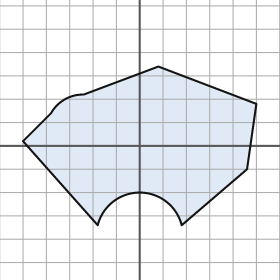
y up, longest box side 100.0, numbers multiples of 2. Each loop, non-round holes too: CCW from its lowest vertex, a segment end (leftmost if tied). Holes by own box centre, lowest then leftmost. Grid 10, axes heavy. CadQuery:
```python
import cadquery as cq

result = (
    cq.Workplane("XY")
    .moveTo(-18.0, -34.0)
    .threePointArc((0.0, -20.0), (18.0, -34.0))
    .lineTo(46.0, -10.0)
    .lineTo(50.0, 18.0)
    .lineTo(8.0, 34.0)
    .lineTo(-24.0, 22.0)
    .threePointArc((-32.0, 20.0), (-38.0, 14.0))
    .lineTo(-50.0, 2.0)
    .close()
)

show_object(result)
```